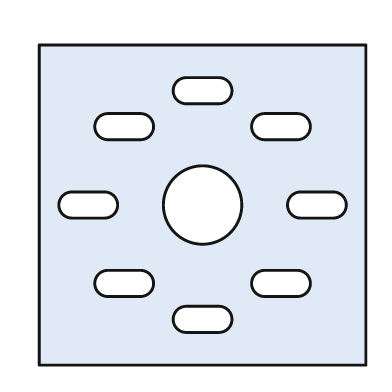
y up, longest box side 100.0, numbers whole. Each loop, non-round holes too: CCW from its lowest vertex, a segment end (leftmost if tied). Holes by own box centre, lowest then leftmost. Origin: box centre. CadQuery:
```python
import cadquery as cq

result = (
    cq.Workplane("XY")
    .moveTo(-50.0, -49.0)
    .lineTo(50.0, -49.0)
    .lineTo(50.0, 49.0)
    .lineTo(-50.0, 49.0)
    .close()
    .moveTo(-5.0, -39.0)
    .lineTo(5.0, -39.0)
    .threePointArc((9.0, -35.0), (5.0, -31.0))
    .lineTo(-5.0, -31.0)
    .threePointArc((-9.0, -35.0), (-5.0, -39.0))
    .close()
    .moveTo(-29.0, -28.0)
    .lineTo(-19.0, -28.0)
    .threePointArc((-15.0, -24.0), (-19.0, -20.0))
    .lineTo(-29.0, -20.0)
    .threePointArc((-33.0, -24.0), (-29.0, -28.0))
    .close()
    .moveTo(19.0, -28.0)
    .lineTo(29.0, -28.0)
    .threePointArc((33.0, -24.0), (29.0, -20.0))
    .lineTo(19.0, -20.0)
    .threePointArc((15.0, -24.0), (19.0, -28.0))
    .close()
    .moveTo(-40.0, -4.0)
    .lineTo(-30.0, -4.0)
    .threePointArc((-26.0, 0.0), (-30.0, 4.0))
    .lineTo(-40.0, 4.0)
    .threePointArc((-44.0, 0.0), (-40.0, -4.0))
    .close()
    .moveTo(0.0, 0.0)
    .circle(12.0)
    .moveTo(30.0, -4.0)
    .lineTo(40.0, -4.0)
    .threePointArc((44.0, 0.0), (40.0, 4.0))
    .lineTo(30.0, 4.0)
    .threePointArc((26.0, 0.0), (30.0, -4.0))
    .close()
    .moveTo(-29.0, 20.0)
    .lineTo(-19.0, 20.0)
    .threePointArc((-15.0, 24.0), (-19.0, 28.0))
    .lineTo(-29.0, 28.0)
    .threePointArc((-33.0, 24.0), (-29.0, 20.0))
    .close()
    .moveTo(19.0, 20.0)
    .lineTo(29.0, 20.0)
    .threePointArc((33.0, 24.0), (29.0, 28.0))
    .lineTo(19.0, 28.0)
    .threePointArc((15.0, 24.0), (19.0, 20.0))
    .close()
    .moveTo(-5.0, 31.0)
    .lineTo(5.0, 31.0)
    .threePointArc((9.0, 35.0), (5.0, 39.0))
    .lineTo(-5.0, 39.0)
    .threePointArc((-9.0, 35.0), (-5.0, 31.0))
    .close()
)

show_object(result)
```